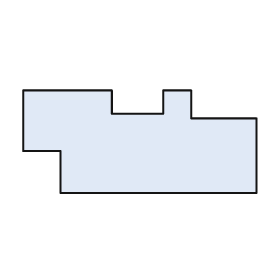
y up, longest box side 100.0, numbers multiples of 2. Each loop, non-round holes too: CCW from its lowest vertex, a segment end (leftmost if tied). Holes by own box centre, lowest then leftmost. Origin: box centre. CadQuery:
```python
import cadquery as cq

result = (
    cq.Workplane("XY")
    .moveTo(-34.0, -22.0)
    .lineTo(50.0, -22.0)
    .lineTo(50.0, 10.0)
    .lineTo(22.0, 10.0)
    .lineTo(22.0, 22.0)
    .lineTo(10.0, 22.0)
    .lineTo(10.0, 12.0)
    .lineTo(-12.0, 12.0)
    .lineTo(-12.0, 22.0)
    .lineTo(-50.0, 22.0)
    .lineTo(-50.0, -4.0)
    .lineTo(-34.0, -4.0)
    .close()
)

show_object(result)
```